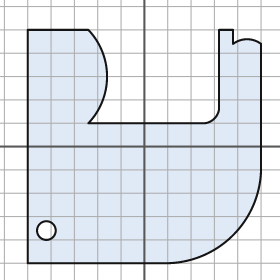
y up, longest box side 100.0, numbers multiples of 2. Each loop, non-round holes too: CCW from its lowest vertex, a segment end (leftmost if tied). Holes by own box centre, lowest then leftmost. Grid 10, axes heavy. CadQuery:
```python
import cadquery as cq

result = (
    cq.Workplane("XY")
    .moveTo(-50.0, -50.0)
    .lineTo(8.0, -50.0)
    .threePointArc((38.0, -38.0), (50.0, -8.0))
    .lineTo(50.0, 44.0)
    .threePointArc((44.0, 46.0), (38.0, 44.0))
    .lineTo(38.0, 50.0)
    .lineTo(32.0, 50.0)
    .lineTo(32.0, 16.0)
    .threePointArc((30.0, 12.0), (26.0, 10.0))
    .lineTo(-24.0, 10.0)
    .threePointArc((-16.0, 30.0), (-24.0, 50.0))
    .lineTo(-50.0, 50.0)
    .close()
    .moveTo(-42.0, -36.0)
    .circle(4.0)
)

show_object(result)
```